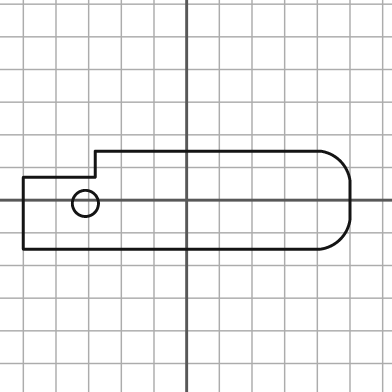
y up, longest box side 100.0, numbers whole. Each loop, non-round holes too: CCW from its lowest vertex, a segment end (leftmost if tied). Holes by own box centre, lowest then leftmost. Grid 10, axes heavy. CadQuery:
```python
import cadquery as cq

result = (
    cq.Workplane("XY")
    .moveTo(-50.0, -15.0)
    .lineTo(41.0, -15.0)
    .threePointArc((47.0, -12.0), (50.0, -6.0))
    .lineTo(50.0, 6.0)
    .threePointArc((47.0, 12.0), (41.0, 15.0))
    .lineTo(-28.0, 15.0)
    .lineTo(-28.0, 7.0)
    .lineTo(-50.0, 7.0)
    .close()
    .moveTo(-31.0, -1.0)
    .circle(4.0)
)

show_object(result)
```